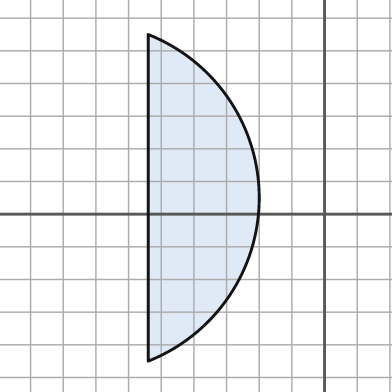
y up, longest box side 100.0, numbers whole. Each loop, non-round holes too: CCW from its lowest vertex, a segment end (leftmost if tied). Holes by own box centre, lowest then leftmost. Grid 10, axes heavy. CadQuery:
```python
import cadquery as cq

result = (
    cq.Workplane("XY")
    .moveTo(-54.0, -45.0)
    .threePointArc((-20.0, 5.0), (-54.0, 55.0))
    .close()
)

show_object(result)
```